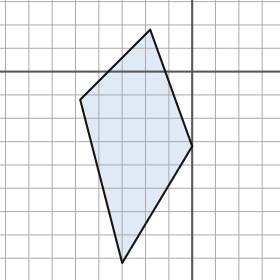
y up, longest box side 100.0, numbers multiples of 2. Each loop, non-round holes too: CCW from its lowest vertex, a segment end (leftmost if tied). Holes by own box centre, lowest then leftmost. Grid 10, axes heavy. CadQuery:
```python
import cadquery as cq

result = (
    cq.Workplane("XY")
    .moveTo(-30.0, -82.0)
    .lineTo(0.0, -32.0)
    .lineTo(-18.0, 18.0)
    .lineTo(-48.0, -12.0)
    .close()
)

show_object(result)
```